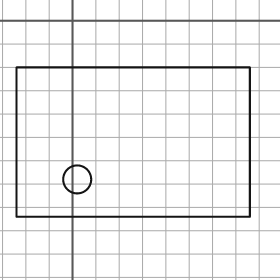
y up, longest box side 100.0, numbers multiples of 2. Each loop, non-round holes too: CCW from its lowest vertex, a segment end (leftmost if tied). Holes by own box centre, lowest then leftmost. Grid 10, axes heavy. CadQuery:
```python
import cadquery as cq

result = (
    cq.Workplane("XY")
    .moveTo(-24.0, -84.0)
    .lineTo(76.0, -84.0)
    .lineTo(76.0, -20.0)
    .lineTo(-24.0, -20.0)
    .close()
    .moveTo(2.0, -68.0)
    .circle(6.0)
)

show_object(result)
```